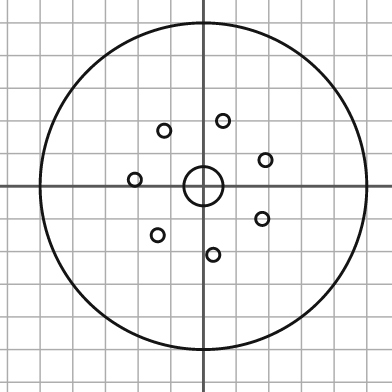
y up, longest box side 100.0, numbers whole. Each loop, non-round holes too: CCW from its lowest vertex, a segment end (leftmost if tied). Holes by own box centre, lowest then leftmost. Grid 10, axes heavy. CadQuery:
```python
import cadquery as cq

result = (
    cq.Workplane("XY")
    .moveTo(0.0, 0.0)
    .circle(50.0)
    .moveTo(3.0, -21.0)
    .circle(2.0)
    .moveTo(-14.0, -15.0)
    .circle(2.0)
    .moveTo(18.0, -10.0)
    .circle(2.0)
    .moveTo(0.0, 0.0)
    .circle(6.0)
    .moveTo(-21.0, 2.0)
    .circle(2.0)
    .moveTo(19.0, 8.0)
    .circle(2.0)
    .moveTo(-12.0, 17.0)
    .circle(2.0)
    .moveTo(6.0, 20.0)
    .circle(2.0)
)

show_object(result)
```